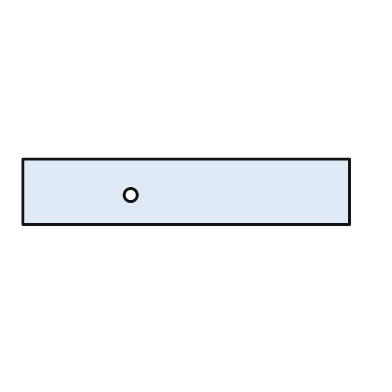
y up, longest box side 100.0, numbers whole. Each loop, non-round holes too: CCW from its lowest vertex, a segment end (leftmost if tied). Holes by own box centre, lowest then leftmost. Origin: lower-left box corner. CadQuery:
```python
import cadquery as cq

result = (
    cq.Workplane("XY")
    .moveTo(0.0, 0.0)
    .lineTo(100.0, 0.0)
    .lineTo(100.0, 20.0)
    .lineTo(0.0, 20.0)
    .close()
    .moveTo(33.0, 9.0)
    .circle(2.0)
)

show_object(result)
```